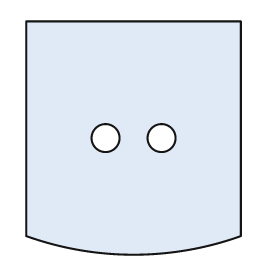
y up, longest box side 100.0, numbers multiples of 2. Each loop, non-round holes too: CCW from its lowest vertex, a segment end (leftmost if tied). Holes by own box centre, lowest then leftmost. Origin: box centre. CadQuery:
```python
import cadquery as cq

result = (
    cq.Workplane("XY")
    .moveTo(-46.0, -42.0)
    .threePointArc((0.0, -50.0), (46.0, -42.0))
    .lineTo(46.0, 50.0)
    .lineTo(-46.0, 50.0)
    .close()
    .moveTo(-12.0, 0.0)
    .circle(6.0)
    .moveTo(12.0, 0.0)
    .circle(6.0)
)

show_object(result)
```